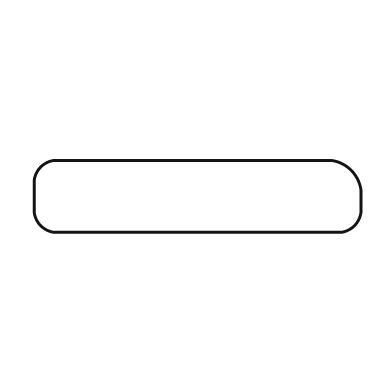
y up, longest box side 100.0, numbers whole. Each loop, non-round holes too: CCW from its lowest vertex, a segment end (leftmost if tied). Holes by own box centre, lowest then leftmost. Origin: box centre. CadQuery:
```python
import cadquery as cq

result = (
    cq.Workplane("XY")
    .moveTo(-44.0, -11.0)
    .lineTo(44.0, -11.0)
    .threePointArc((48.0, -9.0), (50.0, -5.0))
    .lineTo(50.0, 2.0)
    .threePointArc((47.0, 8.0), (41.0, 11.0))
    .lineTo(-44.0, 11.0)
    .threePointArc((-48.0, 9.0), (-50.0, 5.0))
    .lineTo(-50.0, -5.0)
    .threePointArc((-48.0, -9.0), (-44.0, -11.0))
    .close()
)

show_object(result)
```